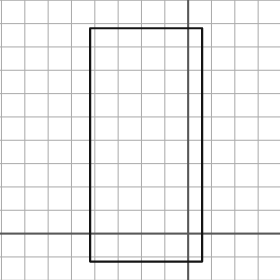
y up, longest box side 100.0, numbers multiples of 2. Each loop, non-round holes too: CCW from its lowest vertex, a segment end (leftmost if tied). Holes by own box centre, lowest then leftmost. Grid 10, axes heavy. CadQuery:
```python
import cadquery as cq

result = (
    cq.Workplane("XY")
    .moveTo(-42.0, -12.0)
    .lineTo(6.0, -12.0)
    .lineTo(6.0, 88.0)
    .lineTo(-42.0, 88.0)
    .close()
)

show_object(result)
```